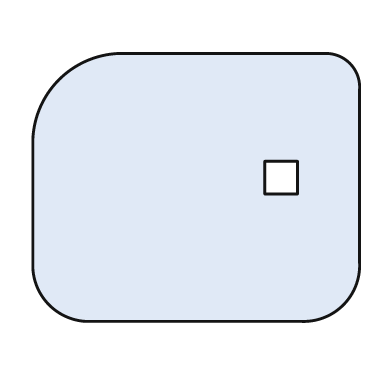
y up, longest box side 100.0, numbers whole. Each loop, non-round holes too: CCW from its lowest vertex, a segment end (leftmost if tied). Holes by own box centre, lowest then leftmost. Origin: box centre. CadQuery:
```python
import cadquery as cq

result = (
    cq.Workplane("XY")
    .moveTo(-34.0, -41.0)
    .lineTo(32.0, -41.0)
    .threePointArc((45.0, -36.0), (50.0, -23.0))
    .lineTo(50.0, 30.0)
    .threePointArc((47.0, 38.0), (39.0, 41.0))
    .lineTo(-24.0, 41.0)
    .threePointArc((-42.0, 33.0), (-50.0, 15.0))
    .lineTo(-50.0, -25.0)
    .threePointArc((-45.0, -36.0), (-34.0, -41.0))
    .close()
    .moveTo(21.0, -2.0)
    .lineTo(31.0, -2.0)
    .lineTo(31.0, 8.0)
    .lineTo(21.0, 8.0)
    .close()
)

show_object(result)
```